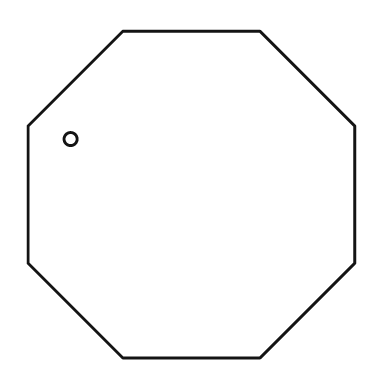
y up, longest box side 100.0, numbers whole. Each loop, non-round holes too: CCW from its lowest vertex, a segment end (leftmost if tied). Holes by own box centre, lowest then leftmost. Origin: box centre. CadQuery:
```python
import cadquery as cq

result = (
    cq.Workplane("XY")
    .moveTo(-21.0, -50.0)
    .lineTo(21.0, -50.0)
    .lineTo(50.0, -21.0)
    .lineTo(50.0, 21.0)
    .lineTo(21.0, 50.0)
    .lineTo(-21.0, 50.0)
    .lineTo(-50.0, 21.0)
    .lineTo(-50.0, -21.0)
    .close()
    .moveTo(-37.0, 17.0)
    .circle(2.0)
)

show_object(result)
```